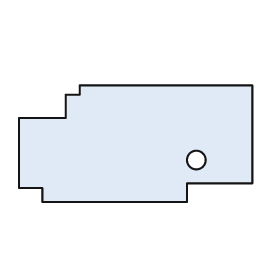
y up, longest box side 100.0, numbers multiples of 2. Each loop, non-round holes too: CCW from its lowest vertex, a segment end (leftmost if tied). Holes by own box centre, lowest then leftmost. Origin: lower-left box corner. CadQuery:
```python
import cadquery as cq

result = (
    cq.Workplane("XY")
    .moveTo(10.0, 0.0)
    .lineTo(72.0, 0.0)
    .lineTo(72.0, 8.0)
    .lineTo(100.0, 8.0)
    .lineTo(100.0, 50.0)
    .lineTo(26.0, 50.0)
    .lineTo(26.0, 46.0)
    .lineTo(20.0, 46.0)
    .lineTo(20.0, 36.0)
    .lineTo(0.0, 36.0)
    .lineTo(0.0, 6.0)
    .lineTo(10.0, 6.0)
    .close()
    .moveTo(76.0, 18.0)
    .circle(4.0)
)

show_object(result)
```